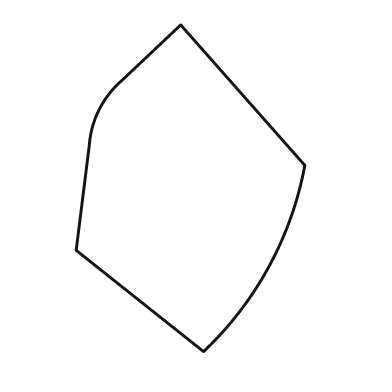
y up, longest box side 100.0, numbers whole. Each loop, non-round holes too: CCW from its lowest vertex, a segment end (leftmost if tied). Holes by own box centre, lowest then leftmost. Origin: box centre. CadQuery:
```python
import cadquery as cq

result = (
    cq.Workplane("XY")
    .moveTo(4.0, -50.0)
    .threePointArc((24.0, -24.0), (35.0, 7.0))
    .lineTo(-3.0, 50.0)
    .lineTo(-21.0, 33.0)
    .threePointArc((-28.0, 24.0), (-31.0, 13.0))
    .lineTo(-35.0, -19.0)
    .close()
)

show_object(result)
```